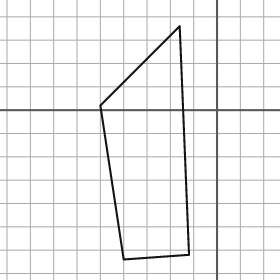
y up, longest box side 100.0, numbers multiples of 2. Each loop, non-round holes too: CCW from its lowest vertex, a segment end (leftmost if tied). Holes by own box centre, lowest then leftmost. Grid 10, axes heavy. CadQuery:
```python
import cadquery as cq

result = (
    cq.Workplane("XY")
    .moveTo(-40.0, -64.0)
    .lineTo(-12.0, -62.0)
    .lineTo(-16.0, 36.0)
    .lineTo(-50.0, 2.0)
    .close()
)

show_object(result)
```